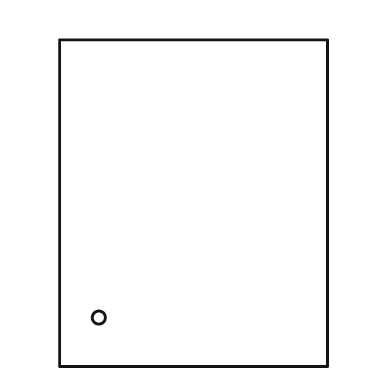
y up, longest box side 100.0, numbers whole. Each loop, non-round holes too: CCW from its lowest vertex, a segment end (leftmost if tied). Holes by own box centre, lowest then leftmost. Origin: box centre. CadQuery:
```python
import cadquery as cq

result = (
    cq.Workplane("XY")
    .moveTo(-41.0, -50.0)
    .lineTo(41.0, -50.0)
    .lineTo(41.0, 50.0)
    .lineTo(-41.0, 50.0)
    .close()
    .moveTo(-29.0, -35.0)
    .circle(2.0)
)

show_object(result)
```